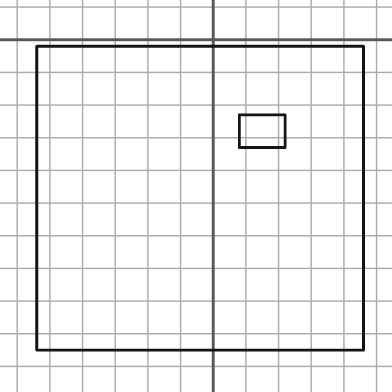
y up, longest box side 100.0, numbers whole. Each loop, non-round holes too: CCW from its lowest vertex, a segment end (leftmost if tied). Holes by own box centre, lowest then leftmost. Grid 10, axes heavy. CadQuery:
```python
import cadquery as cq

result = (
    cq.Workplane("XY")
    .moveTo(-54.0, -95.0)
    .lineTo(46.0, -95.0)
    .lineTo(46.0, -2.0)
    .lineTo(-54.0, -2.0)
    .close()
    .moveTo(8.0, -33.0)
    .lineTo(22.0, -33.0)
    .lineTo(22.0, -23.0)
    .lineTo(8.0, -23.0)
    .close()
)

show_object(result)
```